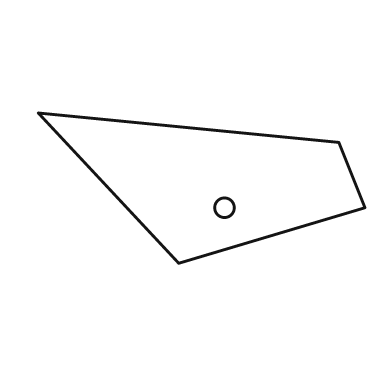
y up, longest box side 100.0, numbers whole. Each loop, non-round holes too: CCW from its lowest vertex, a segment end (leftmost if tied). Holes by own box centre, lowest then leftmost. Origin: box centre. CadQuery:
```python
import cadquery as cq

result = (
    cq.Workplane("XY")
    .moveTo(-7.0, -23.0)
    .lineTo(50.0, -6.0)
    .lineTo(42.0, 14.0)
    .lineTo(-50.0, 23.0)
    .close()
    .moveTo(7.0, -6.0)
    .circle(3.0)
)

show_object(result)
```